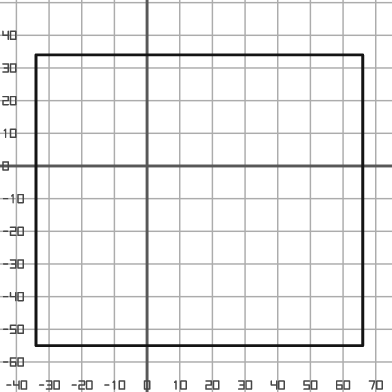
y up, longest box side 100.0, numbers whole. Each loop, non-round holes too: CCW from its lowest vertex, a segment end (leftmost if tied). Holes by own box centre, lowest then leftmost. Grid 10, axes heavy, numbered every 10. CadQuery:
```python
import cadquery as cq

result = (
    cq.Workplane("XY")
    .moveTo(-34.0, -55.0)
    .lineTo(66.0, -55.0)
    .lineTo(66.0, 34.0)
    .lineTo(-34.0, 34.0)
    .close()
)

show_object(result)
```